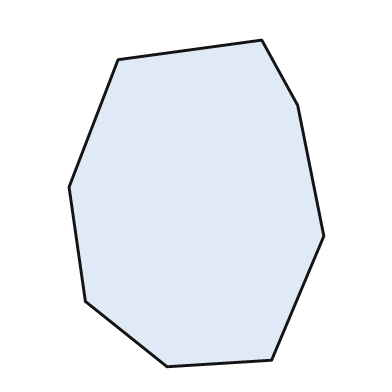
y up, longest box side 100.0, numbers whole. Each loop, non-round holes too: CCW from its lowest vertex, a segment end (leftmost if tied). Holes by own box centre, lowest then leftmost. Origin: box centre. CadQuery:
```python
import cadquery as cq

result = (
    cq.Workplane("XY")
    .moveTo(-9.0, -50.0)
    .lineTo(23.0, -48.0)
    .lineTo(39.0, -10.0)
    .lineTo(31.0, 30.0)
    .lineTo(20.0, 50.0)
    .lineTo(-24.0, 44.0)
    .lineTo(-39.0, 5.0)
    .lineTo(-34.0, -30.0)
    .close()
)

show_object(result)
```